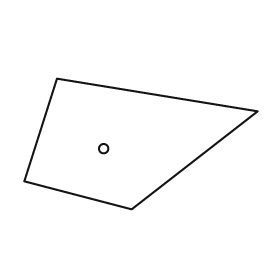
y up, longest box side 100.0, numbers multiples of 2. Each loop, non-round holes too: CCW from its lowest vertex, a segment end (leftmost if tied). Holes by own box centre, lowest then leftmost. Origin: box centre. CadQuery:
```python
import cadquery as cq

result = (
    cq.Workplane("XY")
    .moveTo(-4.0, -28.0)
    .lineTo(50.0, 14.0)
    .lineTo(-36.0, 28.0)
    .lineTo(-50.0, -16.0)
    .close()
    .moveTo(-16.0, -2.0)
    .circle(2.0)
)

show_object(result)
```